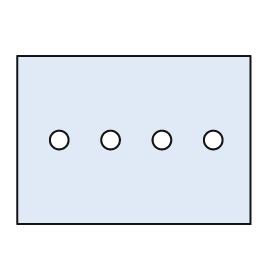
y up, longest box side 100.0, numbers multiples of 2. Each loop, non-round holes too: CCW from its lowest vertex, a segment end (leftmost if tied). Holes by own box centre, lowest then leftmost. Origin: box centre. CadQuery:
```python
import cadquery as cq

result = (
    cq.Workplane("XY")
    .moveTo(-50.0, -36.0)
    .lineTo(50.0, -36.0)
    .lineTo(50.0, 36.0)
    .lineTo(-50.0, 36.0)
    .close()
    .moveTo(-32.0, 0.0)
    .circle(4.0)
    .moveTo(-10.0, 0.0)
    .circle(4.0)
    .moveTo(12.0, 0.0)
    .circle(4.0)
    .moveTo(34.0, 0.0)
    .circle(4.0)
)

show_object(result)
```